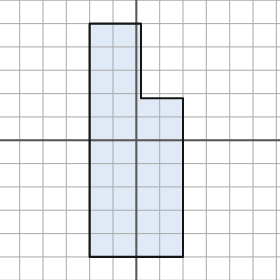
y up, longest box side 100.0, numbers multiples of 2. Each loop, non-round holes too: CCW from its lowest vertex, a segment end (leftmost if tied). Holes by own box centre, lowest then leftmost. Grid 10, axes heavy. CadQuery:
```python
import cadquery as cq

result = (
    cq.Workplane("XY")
    .moveTo(-20.0, -50.0)
    .lineTo(20.0, -50.0)
    .lineTo(20.0, 18.0)
    .lineTo(2.0, 18.0)
    .lineTo(2.0, 50.0)
    .lineTo(-20.0, 50.0)
    .close()
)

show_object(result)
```